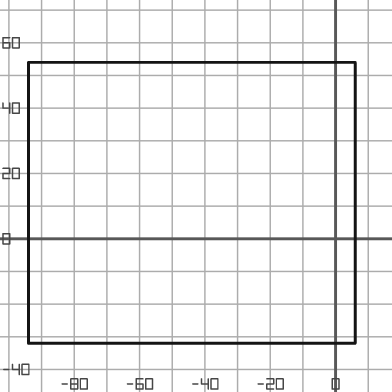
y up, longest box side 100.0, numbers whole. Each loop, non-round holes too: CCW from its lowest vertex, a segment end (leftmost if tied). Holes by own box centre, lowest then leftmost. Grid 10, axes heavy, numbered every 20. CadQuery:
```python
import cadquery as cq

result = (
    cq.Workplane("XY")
    .moveTo(-94.0, -32.0)
    .lineTo(6.0, -32.0)
    .lineTo(6.0, 54.0)
    .lineTo(-94.0, 54.0)
    .close()
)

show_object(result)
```